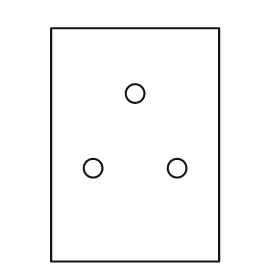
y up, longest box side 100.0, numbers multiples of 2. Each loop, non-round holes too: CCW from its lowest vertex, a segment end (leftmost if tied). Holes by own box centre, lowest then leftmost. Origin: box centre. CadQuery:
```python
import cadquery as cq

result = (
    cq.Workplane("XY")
    .moveTo(-36.0, -50.0)
    .lineTo(36.0, -50.0)
    .lineTo(36.0, 50.0)
    .lineTo(-36.0, 50.0)
    .close()
    .moveTo(-18.0, -10.0)
    .circle(4.0)
    .moveTo(18.0, -10.0)
    .circle(4.0)
    .moveTo(0.0, 22.0)
    .circle(4.0)
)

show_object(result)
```